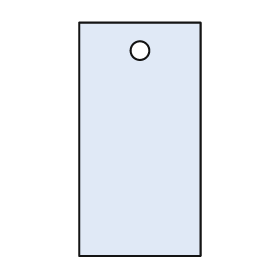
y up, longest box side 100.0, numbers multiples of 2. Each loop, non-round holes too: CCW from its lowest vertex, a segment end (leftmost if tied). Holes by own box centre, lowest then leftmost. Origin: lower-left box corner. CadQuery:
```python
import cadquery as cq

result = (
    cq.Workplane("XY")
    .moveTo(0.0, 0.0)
    .lineTo(52.0, 0.0)
    .lineTo(52.0, 100.0)
    .lineTo(0.0, 100.0)
    .close()
    .moveTo(26.0, 88.0)
    .circle(4.0)
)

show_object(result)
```